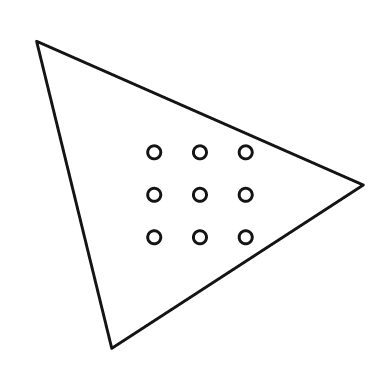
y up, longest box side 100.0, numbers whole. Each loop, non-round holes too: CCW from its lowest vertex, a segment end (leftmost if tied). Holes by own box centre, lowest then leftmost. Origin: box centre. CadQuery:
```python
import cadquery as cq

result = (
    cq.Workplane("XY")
    .moveTo(-27.0, -47.0)
    .lineTo(50.0, 3.0)
    .lineTo(-50.0, 47.0)
    .close()
    .moveTo(-14.0, -13.0)
    .circle(2.0)
    .moveTo(0.0, -13.0)
    .circle(2.0)
    .moveTo(14.0, -13.0)
    .circle(2.0)
    .moveTo(-14.0, 0.0)
    .circle(2.0)
    .moveTo(0.0, 0.0)
    .circle(2.0)
    .moveTo(14.0, 0.0)
    .circle(2.0)
    .moveTo(-14.0, 13.0)
    .circle(2.0)
    .moveTo(0.0, 13.0)
    .circle(2.0)
    .moveTo(14.0, 13.0)
    .circle(2.0)
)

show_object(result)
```